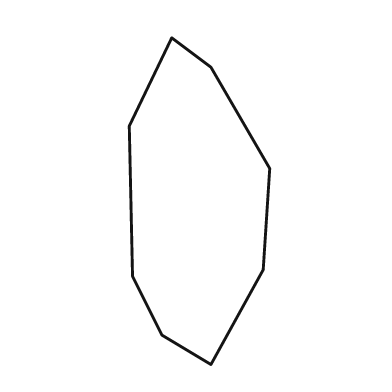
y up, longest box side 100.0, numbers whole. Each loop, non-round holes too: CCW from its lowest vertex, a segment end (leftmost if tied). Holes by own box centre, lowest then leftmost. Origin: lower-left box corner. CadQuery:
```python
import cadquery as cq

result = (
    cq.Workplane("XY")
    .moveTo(25.0, 0.0)
    .lineTo(41.0, 29.0)
    .lineTo(43.0, 60.0)
    .lineTo(25.0, 91.0)
    .lineTo(13.0, 100.0)
    .lineTo(0.0, 73.0)
    .lineTo(1.0, 27.0)
    .lineTo(10.0, 9.0)
    .close()
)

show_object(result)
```